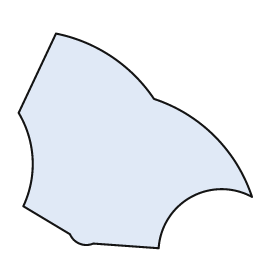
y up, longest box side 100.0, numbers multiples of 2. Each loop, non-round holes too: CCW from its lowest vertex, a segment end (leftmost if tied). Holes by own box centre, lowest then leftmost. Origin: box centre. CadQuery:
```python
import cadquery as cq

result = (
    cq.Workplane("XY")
    .moveTo(10.0, -46.0)
    .threePointArc((24.0, -24.0), (50.0, -24.0))
    .threePointArc((34.0, 2.0), (8.0, 18.0))
    .threePointArc((-10.0, 36.0), (-34.0, 46.0))
    .lineTo(-50.0, 12.0)
    .threePointArc((-44.0, -8.0), (-48.0, -28.0))
    .lineTo(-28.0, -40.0)
    .threePointArc((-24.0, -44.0), (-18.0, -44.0))
    .close()
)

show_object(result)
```